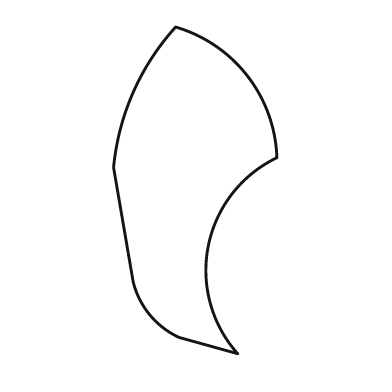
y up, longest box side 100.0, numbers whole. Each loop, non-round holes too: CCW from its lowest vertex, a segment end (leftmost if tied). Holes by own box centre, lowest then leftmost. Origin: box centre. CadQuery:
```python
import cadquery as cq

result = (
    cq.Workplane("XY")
    .moveTo(13.0, -50.0)
    .threePointArc((4.0, -17.0), (25.0, 10.0))
    .threePointArc((16.0, 35.0), (-6.0, 50.0))
    .threePointArc((-19.0, 30.0), (-25.0, 7.0))
    .lineTo(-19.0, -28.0)
    .threePointArc((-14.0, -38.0), (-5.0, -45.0))
    .close()
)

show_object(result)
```